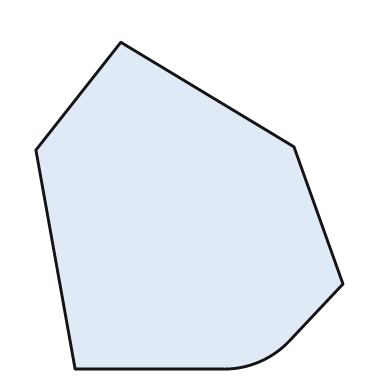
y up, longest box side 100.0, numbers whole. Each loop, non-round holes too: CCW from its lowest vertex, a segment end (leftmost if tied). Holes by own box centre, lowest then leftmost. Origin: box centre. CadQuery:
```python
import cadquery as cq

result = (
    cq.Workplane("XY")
    .moveTo(-35.0, -50.0)
    .lineTo(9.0, -50.0)
    .threePointArc((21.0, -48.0), (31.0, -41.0))
    .lineTo(47.0, -24.0)
    .lineTo(32.0, 18.0)
    .lineTo(-21.0, 50.0)
    .lineTo(-47.0, 17.0)
    .close()
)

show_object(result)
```